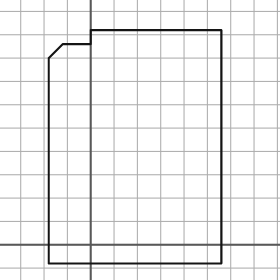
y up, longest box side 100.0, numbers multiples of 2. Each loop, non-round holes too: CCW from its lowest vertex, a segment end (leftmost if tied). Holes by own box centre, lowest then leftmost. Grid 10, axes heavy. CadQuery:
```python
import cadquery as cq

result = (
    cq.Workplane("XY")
    .moveTo(-18.0, -8.0)
    .lineTo(56.0, -8.0)
    .lineTo(56.0, 92.0)
    .lineTo(0.0, 92.0)
    .lineTo(0.0, 86.0)
    .lineTo(-12.0, 86.0)
    .lineTo(-18.0, 80.0)
    .close()
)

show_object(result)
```